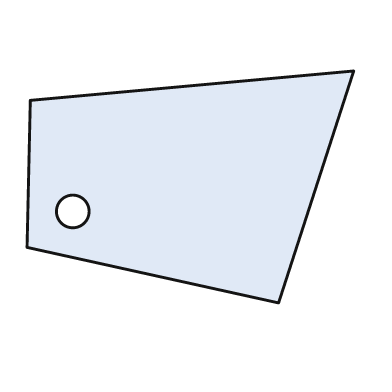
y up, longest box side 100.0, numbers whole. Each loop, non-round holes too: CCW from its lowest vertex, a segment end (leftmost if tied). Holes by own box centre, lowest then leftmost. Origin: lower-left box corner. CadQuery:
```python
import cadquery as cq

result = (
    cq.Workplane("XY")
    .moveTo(77.0, 0.0)
    .lineTo(100.0, 71.0)
    .lineTo(1.0, 62.0)
    .lineTo(0.0, 17.0)
    .close()
    .moveTo(14.0, 28.0)
    .circle(5.0)
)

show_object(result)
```